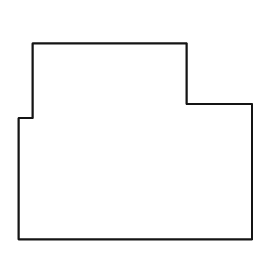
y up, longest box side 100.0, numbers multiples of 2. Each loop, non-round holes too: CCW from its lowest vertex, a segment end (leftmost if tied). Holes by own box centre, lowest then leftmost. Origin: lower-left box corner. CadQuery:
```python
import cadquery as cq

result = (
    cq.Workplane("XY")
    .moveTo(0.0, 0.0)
    .lineTo(100.0, 0.0)
    .lineTo(100.0, 58.0)
    .lineTo(72.0, 58.0)
    .lineTo(72.0, 84.0)
    .lineTo(6.0, 84.0)
    .lineTo(6.0, 52.0)
    .lineTo(0.0, 52.0)
    .close()
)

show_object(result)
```